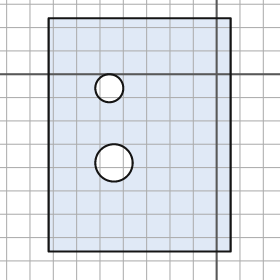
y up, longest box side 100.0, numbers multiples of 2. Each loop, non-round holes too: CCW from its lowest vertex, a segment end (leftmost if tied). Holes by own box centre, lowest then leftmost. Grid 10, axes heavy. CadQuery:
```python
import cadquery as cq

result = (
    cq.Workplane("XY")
    .moveTo(-72.0, -76.0)
    .lineTo(6.0, -76.0)
    .lineTo(6.0, 24.0)
    .lineTo(-72.0, 24.0)
    .close()
    .moveTo(-44.0, -38.0)
    .circle(8.0)
    .moveTo(-46.0, -6.0)
    .circle(6.0)
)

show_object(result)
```